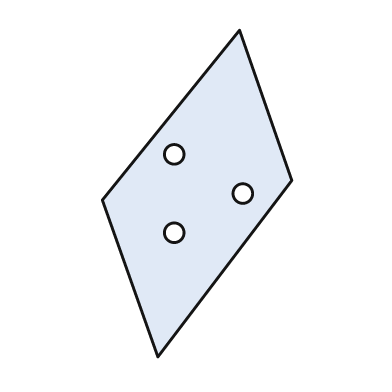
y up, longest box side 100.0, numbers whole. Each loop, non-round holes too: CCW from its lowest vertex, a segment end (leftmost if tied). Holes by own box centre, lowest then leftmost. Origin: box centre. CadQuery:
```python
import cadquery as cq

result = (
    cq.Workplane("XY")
    .moveTo(-12.0, -50.0)
    .lineTo(29.0, 4.0)
    .lineTo(13.0, 50.0)
    .lineTo(-29.0, -2.0)
    .close()
    .moveTo(-7.0, -12.0)
    .circle(3.0)
    .moveTo(14.0, 0.0)
    .circle(3.0)
    .moveTo(-7.0, 12.0)
    .circle(3.0)
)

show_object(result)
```